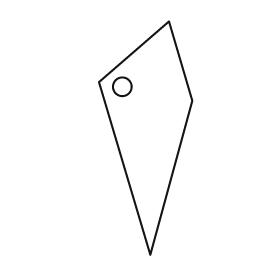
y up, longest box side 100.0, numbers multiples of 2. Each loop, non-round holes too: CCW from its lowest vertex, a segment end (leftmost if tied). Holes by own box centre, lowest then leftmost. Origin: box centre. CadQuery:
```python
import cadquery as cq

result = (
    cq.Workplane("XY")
    .moveTo(2.0, -50.0)
    .lineTo(20.0, 16.0)
    .lineTo(10.0, 50.0)
    .lineTo(-20.0, 24.0)
    .close()
    .moveTo(-10.0, 22.0)
    .circle(4.0)
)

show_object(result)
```